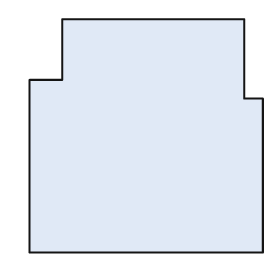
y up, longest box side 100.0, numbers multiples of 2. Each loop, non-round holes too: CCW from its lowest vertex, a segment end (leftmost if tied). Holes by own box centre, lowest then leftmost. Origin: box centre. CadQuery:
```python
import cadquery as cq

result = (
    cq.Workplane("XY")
    .moveTo(-50.0, -50.0)
    .lineTo(50.0, -50.0)
    .lineTo(50.0, 16.0)
    .lineTo(42.0, 16.0)
    .lineTo(42.0, 50.0)
    .lineTo(-36.0, 50.0)
    .lineTo(-36.0, 24.0)
    .lineTo(-50.0, 24.0)
    .close()
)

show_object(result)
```